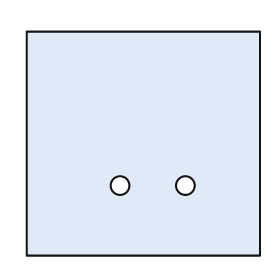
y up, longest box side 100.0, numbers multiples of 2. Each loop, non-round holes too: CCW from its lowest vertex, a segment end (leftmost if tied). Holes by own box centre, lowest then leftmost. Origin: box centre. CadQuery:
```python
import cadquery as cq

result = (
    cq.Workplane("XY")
    .moveTo(-50.0, -48.0)
    .lineTo(50.0, -48.0)
    .lineTo(50.0, 48.0)
    .lineTo(-50.0, 48.0)
    .close()
    .moveTo(-10.0, -18.0)
    .circle(4.0)
    .moveTo(18.0, -18.0)
    .circle(4.0)
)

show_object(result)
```